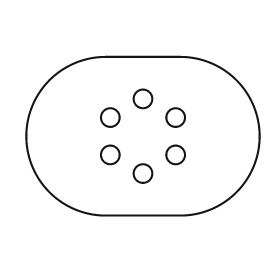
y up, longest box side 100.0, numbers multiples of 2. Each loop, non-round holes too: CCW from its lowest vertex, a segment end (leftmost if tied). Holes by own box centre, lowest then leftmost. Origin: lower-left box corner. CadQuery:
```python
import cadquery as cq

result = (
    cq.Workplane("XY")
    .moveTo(34.0, 0.0)
    .lineTo(66.0, 0.0)
    .threePointArc((100.0, 34.0), (66.0, 68.0))
    .lineTo(34.0, 68.0)
    .threePointArc((0.0, 34.0), (34.0, 0.0))
    .close()
    .moveTo(50.0, 18.0)
    .circle(4.0)
    .moveTo(36.0, 26.0)
    .circle(4.0)
    .moveTo(64.0, 26.0)
    .circle(4.0)
    .moveTo(36.0, 42.0)
    .circle(4.0)
    .moveTo(64.0, 42.0)
    .circle(4.0)
    .moveTo(50.0, 50.0)
    .circle(4.0)
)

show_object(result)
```